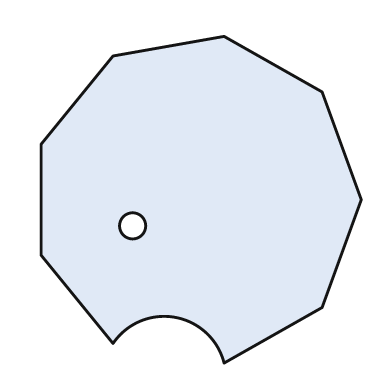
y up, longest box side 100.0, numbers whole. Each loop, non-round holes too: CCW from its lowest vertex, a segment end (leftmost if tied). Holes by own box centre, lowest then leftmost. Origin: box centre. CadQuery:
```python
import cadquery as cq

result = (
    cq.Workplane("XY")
    .moveTo(7.0, -50.0)
    .lineTo(37.0, -33.0)
    .lineTo(49.0, 0.0)
    .lineTo(37.0, 33.0)
    .lineTo(7.0, 50.0)
    .lineTo(-27.0, 44.0)
    .lineTo(-49.0, 17.0)
    .lineTo(-49.0, -17.0)
    .lineTo(-27.0, -44.0)
    .threePointArc((-8.0, -36.0), (7.0, -50.0))
    .close()
    .moveTo(-21.0, -8.0)
    .circle(4.0)
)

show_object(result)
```